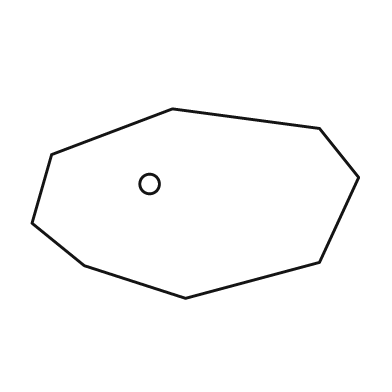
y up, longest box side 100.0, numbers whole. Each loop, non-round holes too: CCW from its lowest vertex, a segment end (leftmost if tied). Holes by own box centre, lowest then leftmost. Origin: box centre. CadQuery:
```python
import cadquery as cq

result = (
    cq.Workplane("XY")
    .moveTo(-3.0, -29.0)
    .lineTo(38.0, -18.0)
    .lineTo(50.0, 8.0)
    .lineTo(38.0, 23.0)
    .lineTo(-7.0, 29.0)
    .lineTo(-44.0, 15.0)
    .lineTo(-50.0, -6.0)
    .lineTo(-34.0, -19.0)
    .close()
    .moveTo(-14.0, 6.0)
    .circle(3.0)
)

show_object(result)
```